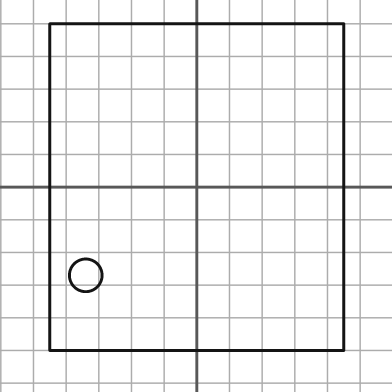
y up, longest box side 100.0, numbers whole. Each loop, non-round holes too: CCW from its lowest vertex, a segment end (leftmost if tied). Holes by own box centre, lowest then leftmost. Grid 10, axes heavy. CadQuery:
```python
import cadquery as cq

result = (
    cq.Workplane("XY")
    .moveTo(-45.0, -50.0)
    .lineTo(45.0, -50.0)
    .lineTo(45.0, 50.0)
    .lineTo(-45.0, 50.0)
    .close()
    .moveTo(-34.0, -27.0)
    .circle(5.0)
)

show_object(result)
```